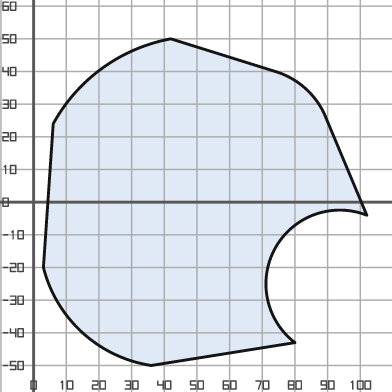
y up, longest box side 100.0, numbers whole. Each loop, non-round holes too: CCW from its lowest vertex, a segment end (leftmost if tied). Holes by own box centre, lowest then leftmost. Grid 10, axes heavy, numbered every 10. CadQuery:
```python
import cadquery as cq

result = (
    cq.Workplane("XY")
    .moveTo(36.0, -50.0)
    .lineTo(80.0, -43.0)
    .threePointArc((74.0, -14.0), (102.0, -4.0))
    .lineTo(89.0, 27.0)
    .threePointArc((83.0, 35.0), (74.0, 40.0))
    .lineTo(42.0, 50.0)
    .threePointArc((21.0, 41.0), (6.0, 24.0))
    .lineTo(3.0, -20.0)
    .threePointArc((15.0, -40.0), (36.0, -50.0))
    .close()
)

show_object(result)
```